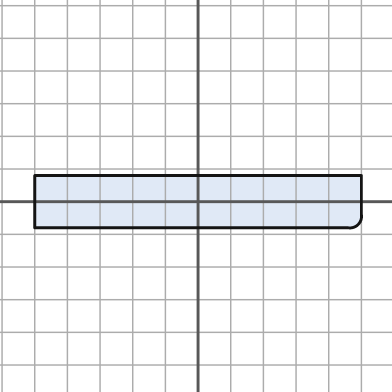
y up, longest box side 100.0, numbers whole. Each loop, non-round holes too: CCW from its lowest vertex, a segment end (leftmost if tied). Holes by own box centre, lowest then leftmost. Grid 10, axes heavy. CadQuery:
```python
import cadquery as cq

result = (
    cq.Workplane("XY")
    .moveTo(-50.0, -8.0)
    .lineTo(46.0, -8.0)
    .threePointArc((49.0, -7.0), (50.0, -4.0))
    .lineTo(50.0, 8.0)
    .lineTo(-50.0, 8.0)
    .close()
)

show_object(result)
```